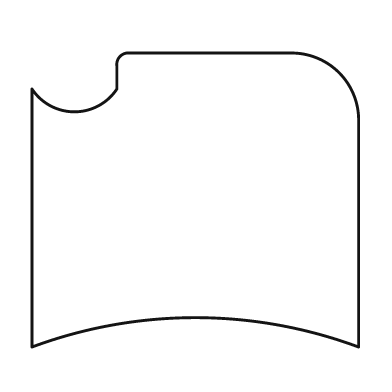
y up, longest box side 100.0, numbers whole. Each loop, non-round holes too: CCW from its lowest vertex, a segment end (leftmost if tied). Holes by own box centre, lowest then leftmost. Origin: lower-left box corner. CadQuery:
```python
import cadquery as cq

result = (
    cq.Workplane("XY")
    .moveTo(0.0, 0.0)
    .threePointArc((50.0, 9.0), (100.0, 0.0))
    .lineTo(100.0, 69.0)
    .threePointArc((94.0, 84.0), (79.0, 90.0))
    .lineTo(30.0, 90.0)
    .threePointArc((27.0, 89.0), (26.0, 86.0))
    .lineTo(26.0, 79.0)
    .threePointArc((13.0, 72.0), (0.0, 79.0))
    .close()
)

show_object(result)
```